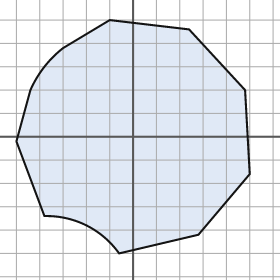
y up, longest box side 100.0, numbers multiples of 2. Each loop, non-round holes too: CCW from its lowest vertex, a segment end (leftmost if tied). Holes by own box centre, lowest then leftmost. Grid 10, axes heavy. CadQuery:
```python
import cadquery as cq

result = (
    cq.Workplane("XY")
    .moveTo(-6.0, -50.0)
    .lineTo(28.0, -42.0)
    .lineTo(50.0, -16.0)
    .lineTo(48.0, 20.0)
    .lineTo(24.0, 46.0)
    .lineTo(-10.0, 50.0)
    .lineTo(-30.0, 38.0)
    .threePointArc((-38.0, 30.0), (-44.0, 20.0))
    .lineTo(-50.0, -2.0)
    .lineTo(-38.0, -34.0)
    .threePointArc((-20.0, -38.0), (-6.0, -50.0))
    .close()
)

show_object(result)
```